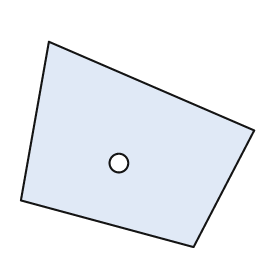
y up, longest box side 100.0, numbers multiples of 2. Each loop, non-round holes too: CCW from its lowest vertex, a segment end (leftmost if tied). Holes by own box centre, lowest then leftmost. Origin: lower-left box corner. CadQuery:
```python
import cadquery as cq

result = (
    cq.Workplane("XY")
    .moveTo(74.0, 0.0)
    .lineTo(100.0, 50.0)
    .lineTo(12.0, 88.0)
    .lineTo(0.0, 20.0)
    .close()
    .moveTo(42.0, 36.0)
    .circle(4.0)
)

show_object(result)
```